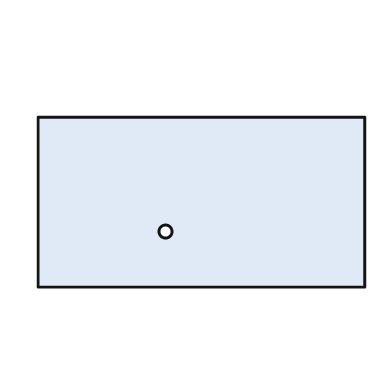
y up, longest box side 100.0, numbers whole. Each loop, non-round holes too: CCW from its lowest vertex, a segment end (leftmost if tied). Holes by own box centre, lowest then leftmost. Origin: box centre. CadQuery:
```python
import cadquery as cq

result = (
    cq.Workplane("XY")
    .moveTo(-50.0, -26.0)
    .lineTo(50.0, -26.0)
    .lineTo(50.0, 26.0)
    .lineTo(-50.0, 26.0)
    .close()
    .moveTo(-11.0, -9.0)
    .circle(2.0)
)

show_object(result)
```